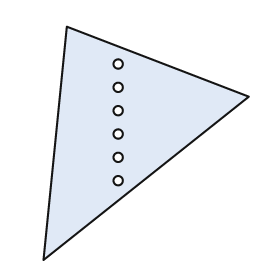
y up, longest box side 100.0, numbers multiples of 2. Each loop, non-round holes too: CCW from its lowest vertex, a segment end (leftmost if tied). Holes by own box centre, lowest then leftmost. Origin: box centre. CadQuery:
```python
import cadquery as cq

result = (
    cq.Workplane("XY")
    .moveTo(-44.0, -50.0)
    .lineTo(44.0, 20.0)
    .lineTo(-34.0, 50.0)
    .close()
    .moveTo(-12.0, -16.0)
    .circle(2.0)
    .moveTo(-12.0, -6.0)
    .circle(2.0)
    .moveTo(-12.0, 4.0)
    .circle(2.0)
    .moveTo(-12.0, 14.0)
    .circle(2.0)
    .moveTo(-12.0, 24.0)
    .circle(2.0)
    .moveTo(-12.0, 34.0)
    .circle(2.0)
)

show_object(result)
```